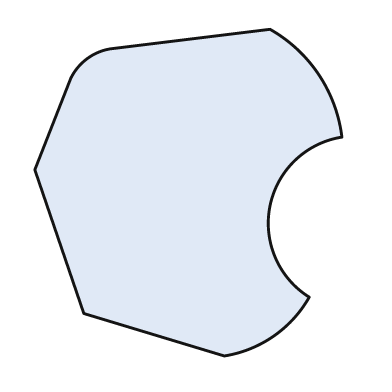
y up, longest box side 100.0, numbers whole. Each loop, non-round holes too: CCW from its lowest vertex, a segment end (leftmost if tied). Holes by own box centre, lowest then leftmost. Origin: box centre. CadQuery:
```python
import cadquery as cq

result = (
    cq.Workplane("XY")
    .moveTo(11.0, -50.0)
    .threePointArc((26.0, -44.0), (37.0, -32.0))
    .threePointArc((25.0, -4.0), (47.0, 17.0))
    .threePointArc((40.0, 36.0), (25.0, 50.0))
    .lineTo(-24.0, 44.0)
    .threePointArc((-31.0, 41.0), (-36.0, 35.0))
    .lineTo(-47.0, 7.0)
    .lineTo(-32.0, -37.0)
    .close()
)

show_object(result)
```